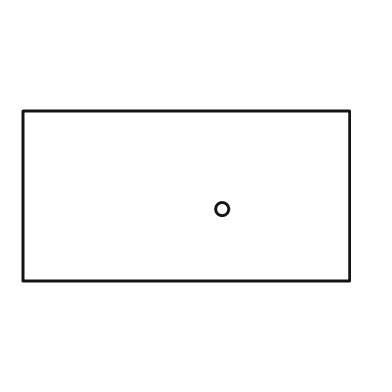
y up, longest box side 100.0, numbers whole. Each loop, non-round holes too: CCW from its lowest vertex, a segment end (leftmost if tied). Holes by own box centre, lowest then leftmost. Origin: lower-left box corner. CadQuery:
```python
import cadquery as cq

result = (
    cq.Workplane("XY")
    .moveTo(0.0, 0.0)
    .lineTo(100.0, 0.0)
    .lineTo(100.0, 52.0)
    .lineTo(0.0, 52.0)
    .close()
    .moveTo(61.0, 22.0)
    .circle(2.0)
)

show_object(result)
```